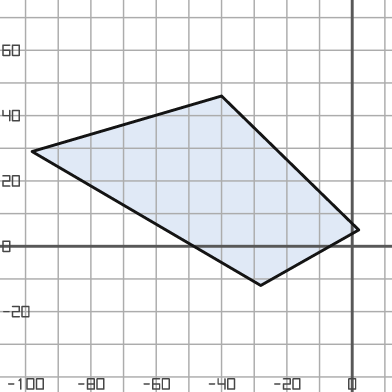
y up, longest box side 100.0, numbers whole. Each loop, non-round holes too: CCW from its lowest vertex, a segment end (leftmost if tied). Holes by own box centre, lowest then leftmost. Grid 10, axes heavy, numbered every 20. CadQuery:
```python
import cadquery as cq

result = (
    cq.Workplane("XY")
    .moveTo(-28.0, -12.0)
    .lineTo(2.0, 5.0)
    .lineTo(-40.0, 46.0)
    .lineTo(-98.0, 29.0)
    .close()
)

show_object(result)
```